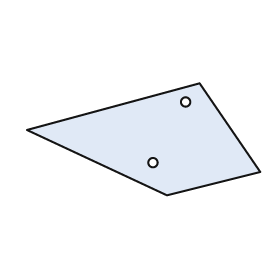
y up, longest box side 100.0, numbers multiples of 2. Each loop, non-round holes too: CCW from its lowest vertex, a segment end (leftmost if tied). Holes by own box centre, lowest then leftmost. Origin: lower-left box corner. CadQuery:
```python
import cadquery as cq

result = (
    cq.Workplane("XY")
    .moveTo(60.0, 0.0)
    .lineTo(100.0, 10.0)
    .lineTo(74.0, 48.0)
    .lineTo(0.0, 28.0)
    .close()
    .moveTo(54.0, 14.0)
    .circle(2.0)
    .moveTo(68.0, 40.0)
    .circle(2.0)
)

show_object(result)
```